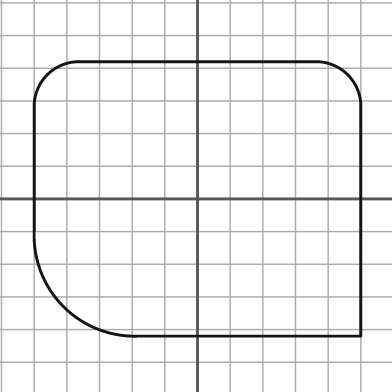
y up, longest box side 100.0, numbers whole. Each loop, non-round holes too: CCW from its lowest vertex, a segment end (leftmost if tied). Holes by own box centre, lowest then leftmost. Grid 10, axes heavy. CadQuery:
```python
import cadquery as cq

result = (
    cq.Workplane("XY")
    .moveTo(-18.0, -42.0)
    .lineTo(50.0, -42.0)
    .lineTo(50.0, 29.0)
    .threePointArc((46.0, 38.0), (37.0, 42.0))
    .lineTo(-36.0, 42.0)
    .threePointArc((-46.0, 38.0), (-50.0, 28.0))
    .lineTo(-50.0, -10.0)
    .threePointArc((-41.0, -33.0), (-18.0, -42.0))
    .close()
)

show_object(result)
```